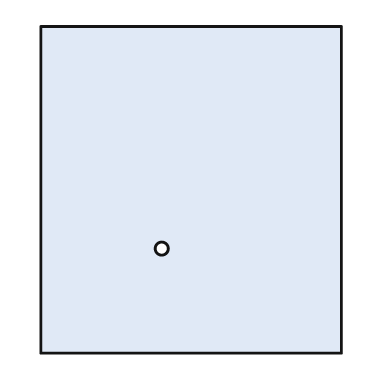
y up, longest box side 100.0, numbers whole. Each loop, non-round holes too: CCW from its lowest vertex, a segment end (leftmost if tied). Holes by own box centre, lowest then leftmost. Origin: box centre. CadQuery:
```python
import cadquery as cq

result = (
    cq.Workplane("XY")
    .moveTo(-46.0, -50.0)
    .lineTo(46.0, -50.0)
    .lineTo(46.0, 50.0)
    .lineTo(-46.0, 50.0)
    .close()
    .moveTo(-9.0, -18.0)
    .circle(2.0)
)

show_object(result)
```